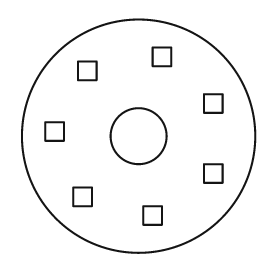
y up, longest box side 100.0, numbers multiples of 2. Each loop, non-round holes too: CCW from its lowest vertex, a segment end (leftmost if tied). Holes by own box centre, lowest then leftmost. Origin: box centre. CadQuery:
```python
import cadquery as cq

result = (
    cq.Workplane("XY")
    .moveTo(0.0, 0.0)
    .circle(50.0)
    .moveTo(2.0, -38.0)
    .lineTo(10.0, -38.0)
    .lineTo(10.0, -30.0)
    .lineTo(2.0, -30.0)
    .close()
    .moveTo(-28.0, -30.0)
    .lineTo(-20.0, -30.0)
    .lineTo(-20.0, -22.0)
    .lineTo(-28.0, -22.0)
    .close()
    .moveTo(28.0, -20.0)
    .lineTo(36.0, -20.0)
    .lineTo(36.0, -12.0)
    .lineTo(28.0, -12.0)
    .close()
    .moveTo(0.0, 0.0)
    .circle(12.0)
    .moveTo(-40.0, -2.0)
    .lineTo(-32.0, -2.0)
    .lineTo(-32.0, 6.0)
    .lineTo(-40.0, 6.0)
    .close()
    .moveTo(28.0, 10.0)
    .lineTo(36.0, 10.0)
    .lineTo(36.0, 18.0)
    .lineTo(28.0, 18.0)
    .close()
    .moveTo(-26.0, 24.0)
    .lineTo(-18.0, 24.0)
    .lineTo(-18.0, 32.0)
    .lineTo(-26.0, 32.0)
    .close()
    .moveTo(6.0, 30.0)
    .lineTo(14.0, 30.0)
    .lineTo(14.0, 38.0)
    .lineTo(6.0, 38.0)
    .close()
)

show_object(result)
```